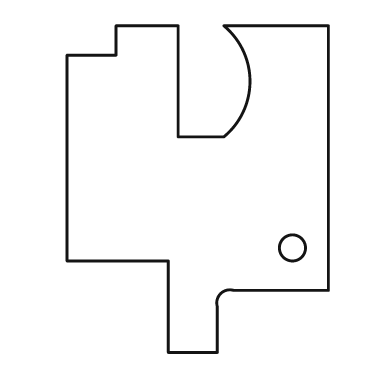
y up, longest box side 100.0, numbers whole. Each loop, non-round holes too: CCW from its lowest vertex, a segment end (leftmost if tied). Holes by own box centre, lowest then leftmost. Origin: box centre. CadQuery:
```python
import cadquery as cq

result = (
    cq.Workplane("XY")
    .moveTo(-9.0, -50.0)
    .lineTo(6.0, -50.0)
    .lineTo(6.0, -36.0)
    .threePointArc((7.0, -32.0), (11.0, -31.0))
    .lineTo(40.0, -31.0)
    .lineTo(40.0, 50.0)
    .lineTo(8.0, 50.0)
    .threePointArc((16.0, 33.0), (8.0, 16.0))
    .lineTo(-6.0, 16.0)
    .lineTo(-6.0, 50.0)
    .lineTo(-25.0, 50.0)
    .lineTo(-25.0, 41.0)
    .lineTo(-40.0, 41.0)
    .lineTo(-40.0, -22.0)
    .lineTo(-9.0, -22.0)
    .close()
    .moveTo(29.0, -18.0)
    .circle(4.0)
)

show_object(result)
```